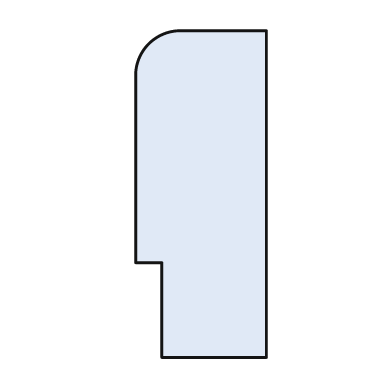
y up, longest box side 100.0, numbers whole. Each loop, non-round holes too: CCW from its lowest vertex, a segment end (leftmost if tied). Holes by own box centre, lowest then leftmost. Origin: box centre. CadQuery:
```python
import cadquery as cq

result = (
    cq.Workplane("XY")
    .moveTo(-12.0, -50.0)
    .lineTo(20.0, -50.0)
    .lineTo(20.0, 50.0)
    .lineTo(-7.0, 50.0)
    .threePointArc((-16.0, 46.0), (-20.0, 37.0))
    .lineTo(-20.0, -21.0)
    .lineTo(-12.0, -21.0)
    .close()
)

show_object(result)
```